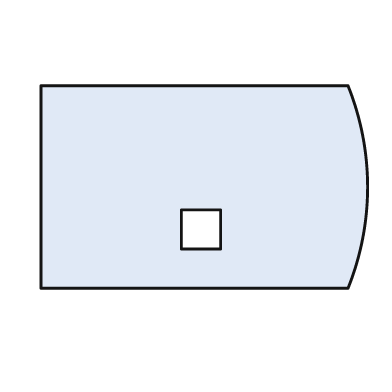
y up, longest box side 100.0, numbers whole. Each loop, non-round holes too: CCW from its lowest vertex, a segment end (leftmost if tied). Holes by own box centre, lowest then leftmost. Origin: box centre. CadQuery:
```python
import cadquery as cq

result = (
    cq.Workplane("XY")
    .moveTo(-50.0, -31.0)
    .lineTo(44.0, -31.0)
    .threePointArc((50.0, 0.0), (44.0, 31.0))
    .lineTo(-50.0, 31.0)
    .close()
    .moveTo(-7.0, -19.0)
    .lineTo(5.0, -19.0)
    .lineTo(5.0, -7.0)
    .lineTo(-7.0, -7.0)
    .close()
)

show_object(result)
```